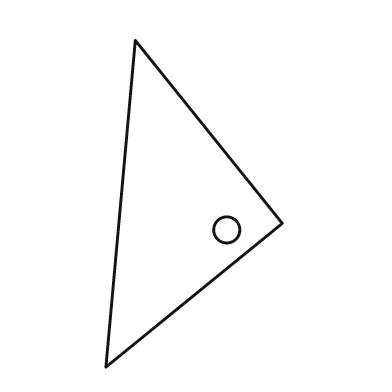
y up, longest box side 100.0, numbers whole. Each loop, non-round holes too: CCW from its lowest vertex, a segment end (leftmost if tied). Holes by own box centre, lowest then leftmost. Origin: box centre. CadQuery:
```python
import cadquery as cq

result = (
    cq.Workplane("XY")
    .moveTo(-27.0, -50.0)
    .lineTo(27.0, -6.0)
    .lineTo(-18.0, 50.0)
    .close()
    .moveTo(10.0, -8.0)
    .circle(4.0)
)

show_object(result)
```